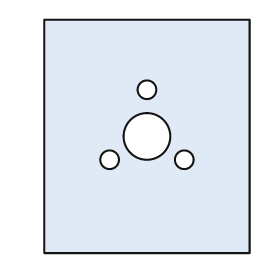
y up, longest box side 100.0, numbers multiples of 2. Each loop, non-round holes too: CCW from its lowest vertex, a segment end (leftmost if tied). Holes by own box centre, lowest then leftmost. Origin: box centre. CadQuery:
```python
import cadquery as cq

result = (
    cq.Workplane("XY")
    .moveTo(-44.0, -50.0)
    .lineTo(44.0, -50.0)
    .lineTo(44.0, 50.0)
    .lineTo(-44.0, 50.0)
    .close()
    .moveTo(-16.0, -10.0)
    .circle(4.0)
    .moveTo(16.0, -10.0)
    .circle(4.0)
    .moveTo(0.0, 0.0)
    .circle(10.0)
    .moveTo(0.0, 20.0)
    .circle(4.0)
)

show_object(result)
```